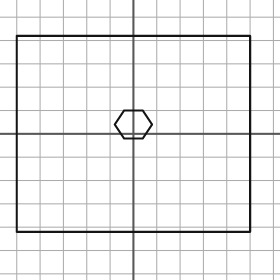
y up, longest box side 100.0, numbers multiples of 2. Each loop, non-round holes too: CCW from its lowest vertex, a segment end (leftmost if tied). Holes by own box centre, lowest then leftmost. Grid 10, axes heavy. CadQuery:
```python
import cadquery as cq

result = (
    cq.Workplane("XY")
    .moveTo(-50.0, -42.0)
    .lineTo(50.0, -42.0)
    .lineTo(50.0, 42.0)
    .lineTo(-50.0, 42.0)
    .close()
    .moveTo(-4.0, -2.0)
    .lineTo(4.0, -2.0)
    .lineTo(8.0, 4.0)
    .lineTo(4.0, 10.0)
    .lineTo(-4.0, 10.0)
    .lineTo(-8.0, 4.0)
    .close()
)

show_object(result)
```